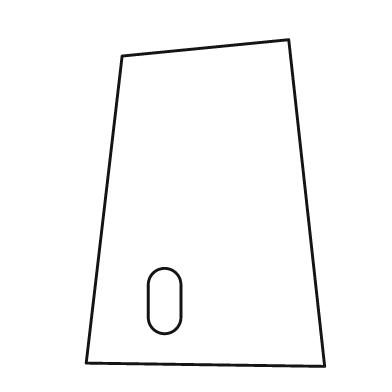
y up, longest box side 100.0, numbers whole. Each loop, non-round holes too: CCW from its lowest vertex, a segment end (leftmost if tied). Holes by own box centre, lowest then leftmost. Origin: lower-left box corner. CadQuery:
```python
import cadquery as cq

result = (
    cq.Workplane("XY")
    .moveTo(73.0, 0.0)
    .lineTo(62.0, 100.0)
    .lineTo(11.0, 95.0)
    .lineTo(0.0, 1.0)
    .close()
    .moveTo(19.0, 15.0)
    .threePointArc((24.0, 10.0), (29.0, 15.0))
    .lineTo(29.0, 25.0)
    .threePointArc((24.0, 30.0), (19.0, 25.0))
    .close()
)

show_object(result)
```